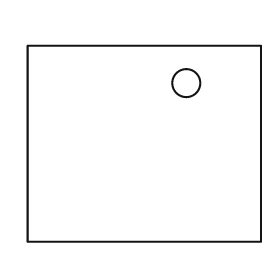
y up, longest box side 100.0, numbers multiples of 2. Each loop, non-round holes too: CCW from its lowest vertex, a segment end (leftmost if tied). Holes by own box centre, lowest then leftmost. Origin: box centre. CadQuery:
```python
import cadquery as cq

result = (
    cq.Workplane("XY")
    .moveTo(-50.0, -42.0)
    .lineTo(50.0, -42.0)
    .lineTo(50.0, 42.0)
    .lineTo(-50.0, 42.0)
    .close()
    .moveTo(18.0, 26.0)
    .circle(6.0)
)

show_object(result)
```